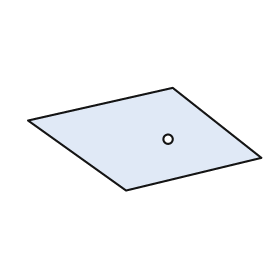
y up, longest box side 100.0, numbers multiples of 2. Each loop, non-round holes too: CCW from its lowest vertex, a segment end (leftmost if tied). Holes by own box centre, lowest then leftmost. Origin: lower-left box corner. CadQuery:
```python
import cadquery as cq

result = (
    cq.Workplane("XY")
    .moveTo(42.0, 0.0)
    .lineTo(100.0, 14.0)
    .lineTo(62.0, 44.0)
    .lineTo(0.0, 30.0)
    .close()
    .moveTo(60.0, 22.0)
    .circle(2.0)
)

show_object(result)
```